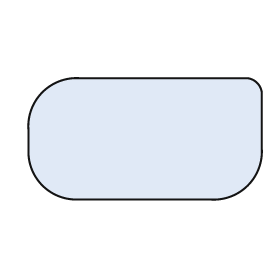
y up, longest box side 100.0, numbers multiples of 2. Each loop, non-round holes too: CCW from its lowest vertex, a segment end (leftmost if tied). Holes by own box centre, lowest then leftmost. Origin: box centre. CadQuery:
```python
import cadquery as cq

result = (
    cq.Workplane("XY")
    .moveTo(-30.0, -26.0)
    .lineTo(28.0, -26.0)
    .threePointArc((44.0, -20.0), (50.0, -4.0))
    .lineTo(50.0, 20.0)
    .threePointArc((48.0, 24.0), (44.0, 26.0))
    .lineTo(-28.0, 26.0)
    .threePointArc((-44.0, 20.0), (-50.0, 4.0))
    .lineTo(-50.0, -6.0)
    .threePointArc((-44.0, -20.0), (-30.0, -26.0))
    .close()
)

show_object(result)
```